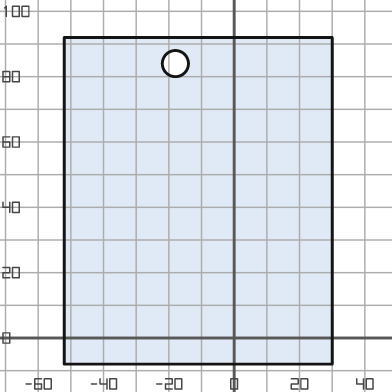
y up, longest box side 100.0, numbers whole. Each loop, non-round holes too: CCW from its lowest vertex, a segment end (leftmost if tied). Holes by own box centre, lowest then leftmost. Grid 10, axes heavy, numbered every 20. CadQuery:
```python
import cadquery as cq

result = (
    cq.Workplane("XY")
    .moveTo(-52.0, -8.0)
    .lineTo(30.0, -8.0)
    .lineTo(30.0, 92.0)
    .lineTo(-52.0, 92.0)
    .close()
    .moveTo(-18.0, 84.0)
    .circle(4.0)
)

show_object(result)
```